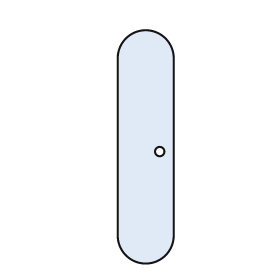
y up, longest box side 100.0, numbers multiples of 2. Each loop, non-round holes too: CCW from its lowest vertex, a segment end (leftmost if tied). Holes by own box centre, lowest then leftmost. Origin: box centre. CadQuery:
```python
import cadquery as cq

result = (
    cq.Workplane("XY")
    .moveTo(-12.0, -38.0)
    .threePointArc((0.0, -50.0), (12.0, -38.0))
    .lineTo(12.0, 38.0)
    .threePointArc((0.0, 50.0), (-12.0, 38.0))
    .close()
    .moveTo(6.0, -2.0)
    .circle(2.0)
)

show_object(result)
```